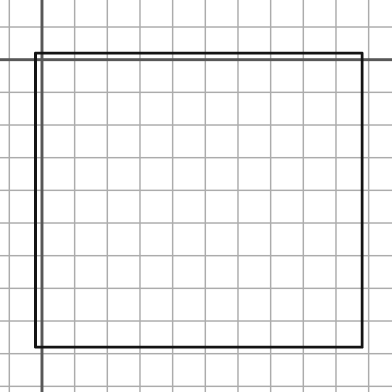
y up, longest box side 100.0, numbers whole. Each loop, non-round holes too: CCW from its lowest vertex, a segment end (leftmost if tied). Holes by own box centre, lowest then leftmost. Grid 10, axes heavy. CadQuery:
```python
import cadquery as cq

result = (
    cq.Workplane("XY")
    .moveTo(-2.0, -88.0)
    .lineTo(98.0, -88.0)
    .lineTo(98.0, 2.0)
    .lineTo(-2.0, 2.0)
    .close()
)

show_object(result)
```